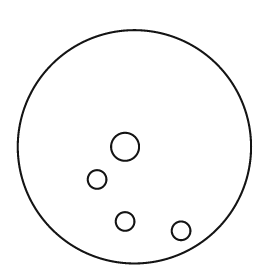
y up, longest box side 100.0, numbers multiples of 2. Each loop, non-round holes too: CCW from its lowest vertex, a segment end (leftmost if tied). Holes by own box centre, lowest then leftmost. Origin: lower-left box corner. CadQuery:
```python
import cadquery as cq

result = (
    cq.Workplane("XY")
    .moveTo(50.0, 50.0)
    .circle(50.0)
    .moveTo(70.0, 14.0)
    .circle(4.0)
    .moveTo(46.0, 18.0)
    .circle(4.0)
    .moveTo(34.0, 36.0)
    .circle(4.0)
    .moveTo(46.0, 50.0)
    .circle(6.0)
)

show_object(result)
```